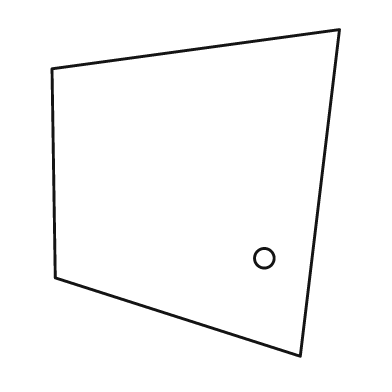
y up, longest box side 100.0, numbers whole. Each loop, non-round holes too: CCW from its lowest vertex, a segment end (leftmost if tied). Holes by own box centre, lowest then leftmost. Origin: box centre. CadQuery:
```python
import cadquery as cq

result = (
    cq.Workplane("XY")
    .moveTo(32.0, -50.0)
    .lineTo(44.0, 50.0)
    .lineTo(-44.0, 38.0)
    .lineTo(-43.0, -26.0)
    .close()
    .moveTo(21.0, -20.0)
    .circle(3.0)
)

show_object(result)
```